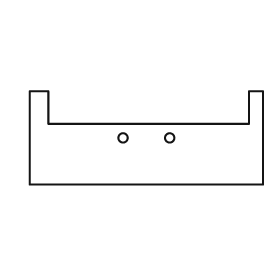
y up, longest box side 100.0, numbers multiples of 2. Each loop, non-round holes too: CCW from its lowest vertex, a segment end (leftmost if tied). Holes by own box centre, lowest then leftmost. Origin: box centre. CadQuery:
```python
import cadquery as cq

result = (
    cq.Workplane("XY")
    .moveTo(-50.0, -20.0)
    .lineTo(50.0, -20.0)
    .lineTo(50.0, 20.0)
    .lineTo(44.0, 20.0)
    .lineTo(44.0, 6.0)
    .lineTo(-42.0, 6.0)
    .lineTo(-42.0, 20.0)
    .lineTo(-50.0, 20.0)
    .close()
    .moveTo(-10.0, 0.0)
    .circle(2.0)
    .moveTo(10.0, 0.0)
    .circle(2.0)
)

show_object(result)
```